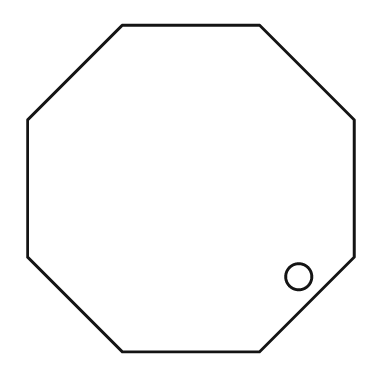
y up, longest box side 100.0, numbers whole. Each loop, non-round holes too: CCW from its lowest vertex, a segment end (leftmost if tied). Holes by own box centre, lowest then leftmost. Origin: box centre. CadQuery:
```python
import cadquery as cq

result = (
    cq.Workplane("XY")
    .moveTo(-21.0, -50.0)
    .lineTo(21.0, -50.0)
    .lineTo(50.0, -21.0)
    .lineTo(50.0, 21.0)
    .lineTo(21.0, 50.0)
    .lineTo(-21.0, 50.0)
    .lineTo(-50.0, 21.0)
    .lineTo(-50.0, -21.0)
    .close()
    .moveTo(33.0, -27.0)
    .circle(4.0)
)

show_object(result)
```